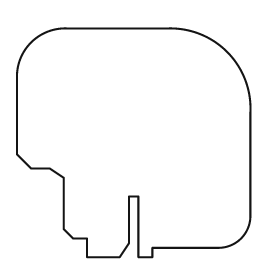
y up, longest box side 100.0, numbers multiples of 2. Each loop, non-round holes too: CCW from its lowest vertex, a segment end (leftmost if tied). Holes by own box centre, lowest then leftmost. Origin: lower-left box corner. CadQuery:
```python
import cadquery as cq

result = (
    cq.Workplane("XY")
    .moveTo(30.0, 0.0)
    .lineTo(44.0, 0.0)
    .lineTo(48.0, 6.0)
    .lineTo(48.0, 26.0)
    .lineTo(52.0, 26.0)
    .lineTo(52.0, 0.0)
    .lineTo(58.0, 0.0)
    .lineTo(58.0, 4.0)
    .lineTo(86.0, 4.0)
    .threePointArc((96.0, 8.0), (100.0, 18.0))
    .lineTo(100.0, 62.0)
    .threePointArc((90.0, 88.0), (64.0, 98.0))
    .lineTo(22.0, 98.0)
    .threePointArc((6.0, 92.0), (0.0, 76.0))
    .lineTo(0.0, 44.0)
    .lineTo(6.0, 38.0)
    .lineTo(14.0, 38.0)
    .lineTo(20.0, 34.0)
    .lineTo(20.0, 12.0)
    .lineTo(24.0, 8.0)
    .lineTo(30.0, 8.0)
    .close()
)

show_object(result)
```